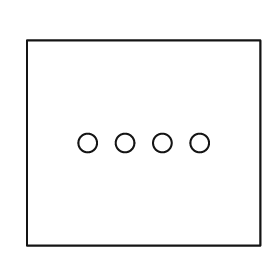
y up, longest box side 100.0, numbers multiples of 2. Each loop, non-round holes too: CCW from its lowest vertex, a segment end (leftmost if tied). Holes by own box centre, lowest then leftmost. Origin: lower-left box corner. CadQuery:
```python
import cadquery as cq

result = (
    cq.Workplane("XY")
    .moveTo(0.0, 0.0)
    .lineTo(100.0, 0.0)
    .lineTo(100.0, 88.0)
    .lineTo(0.0, 88.0)
    .close()
    .moveTo(26.0, 44.0)
    .circle(4.0)
    .moveTo(42.0, 44.0)
    .circle(4.0)
    .moveTo(58.0, 44.0)
    .circle(4.0)
    .moveTo(74.0, 44.0)
    .circle(4.0)
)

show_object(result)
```